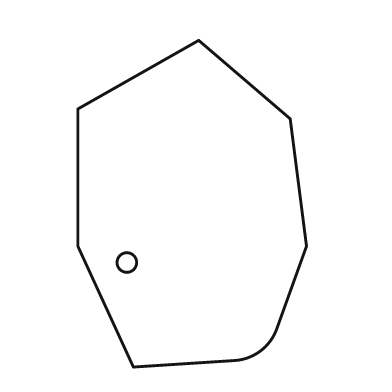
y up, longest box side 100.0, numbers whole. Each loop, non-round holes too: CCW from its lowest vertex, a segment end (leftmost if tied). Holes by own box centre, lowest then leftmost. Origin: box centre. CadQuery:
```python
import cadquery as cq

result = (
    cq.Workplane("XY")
    .moveTo(-18.0, -50.0)
    .lineTo(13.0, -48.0)
    .threePointArc((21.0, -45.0), (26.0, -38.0))
    .lineTo(35.0, -13.0)
    .lineTo(30.0, 26.0)
    .lineTo(2.0, 50.0)
    .lineTo(-35.0, 29.0)
    .lineTo(-35.0, -13.0)
    .close()
    .moveTo(-20.0, -18.0)
    .circle(3.0)
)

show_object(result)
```